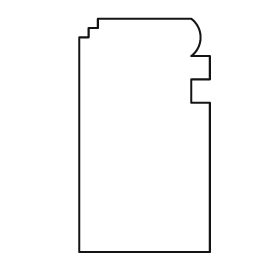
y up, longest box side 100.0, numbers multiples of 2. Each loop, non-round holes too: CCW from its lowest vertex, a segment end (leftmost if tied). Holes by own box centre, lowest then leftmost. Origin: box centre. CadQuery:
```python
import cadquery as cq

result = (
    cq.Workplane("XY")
    .moveTo(-28.0, -50.0)
    .lineTo(28.0, -50.0)
    .lineTo(28.0, 14.0)
    .lineTo(20.0, 14.0)
    .lineTo(20.0, 24.0)
    .lineTo(28.0, 24.0)
    .lineTo(28.0, 34.0)
    .lineTo(20.0, 34.0)
    .threePointArc((24.0, 42.0), (20.0, 50.0))
    .lineTo(-20.0, 50.0)
    .lineTo(-20.0, 46.0)
    .lineTo(-24.0, 46.0)
    .lineTo(-24.0, 42.0)
    .lineTo(-28.0, 42.0)
    .close()
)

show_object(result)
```